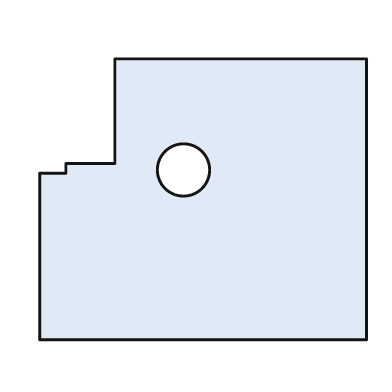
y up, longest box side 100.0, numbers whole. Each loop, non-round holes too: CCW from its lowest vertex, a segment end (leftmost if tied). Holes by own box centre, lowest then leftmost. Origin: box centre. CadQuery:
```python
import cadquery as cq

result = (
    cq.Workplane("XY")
    .moveTo(-50.0, -43.0)
    .lineTo(50.0, -43.0)
    .lineTo(50.0, 43.0)
    .lineTo(-27.0, 43.0)
    .lineTo(-27.0, 11.0)
    .lineTo(-42.0, 11.0)
    .lineTo(-42.0, 8.0)
    .lineTo(-50.0, 8.0)
    .close()
    .moveTo(-6.0, 9.0)
    .circle(8.0)
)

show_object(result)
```